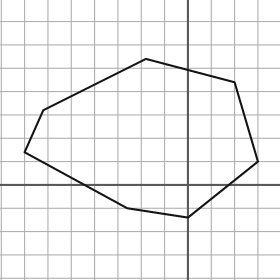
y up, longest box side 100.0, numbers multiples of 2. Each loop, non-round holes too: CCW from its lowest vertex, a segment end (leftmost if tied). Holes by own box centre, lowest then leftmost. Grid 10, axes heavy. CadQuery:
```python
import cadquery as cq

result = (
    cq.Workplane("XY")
    .moveTo(0.0, -14.0)
    .lineTo(30.0, 10.0)
    .lineTo(20.0, 44.0)
    .lineTo(-18.0, 54.0)
    .lineTo(-62.0, 32.0)
    .lineTo(-70.0, 14.0)
    .lineTo(-26.0, -10.0)
    .close()
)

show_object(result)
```